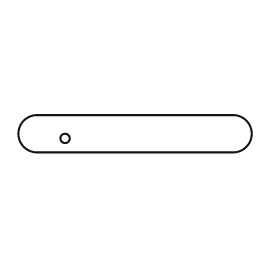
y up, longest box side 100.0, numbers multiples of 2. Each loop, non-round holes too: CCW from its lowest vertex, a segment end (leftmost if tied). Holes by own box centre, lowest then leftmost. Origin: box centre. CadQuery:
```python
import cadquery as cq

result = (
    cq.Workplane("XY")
    .moveTo(-42.0, -8.0)
    .lineTo(42.0, -8.0)
    .threePointArc((50.0, 0.0), (42.0, 8.0))
    .lineTo(-42.0, 8.0)
    .threePointArc((-50.0, 0.0), (-42.0, -8.0))
    .close()
    .moveTo(-30.0, -2.0)
    .circle(2.0)
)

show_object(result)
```